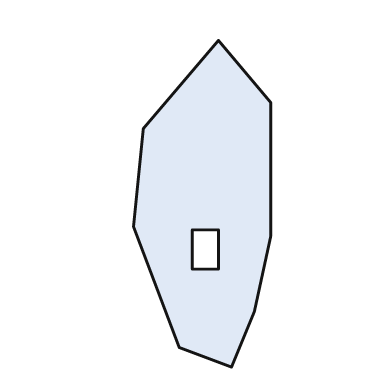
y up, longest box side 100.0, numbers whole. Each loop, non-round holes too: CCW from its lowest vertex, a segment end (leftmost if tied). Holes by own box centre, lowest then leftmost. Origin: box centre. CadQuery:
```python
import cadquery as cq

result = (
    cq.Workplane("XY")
    .moveTo(9.0, -50.0)
    .lineTo(16.0, -33.0)
    .lineTo(21.0, -10.0)
    .lineTo(21.0, 31.0)
    .lineTo(5.0, 50.0)
    .lineTo(-18.0, 23.0)
    .lineTo(-21.0, -7.0)
    .lineTo(-7.0, -44.0)
    .close()
    .moveTo(-3.0, -20.0)
    .lineTo(5.0, -20.0)
    .lineTo(5.0, -8.0)
    .lineTo(-3.0, -8.0)
    .close()
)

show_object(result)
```